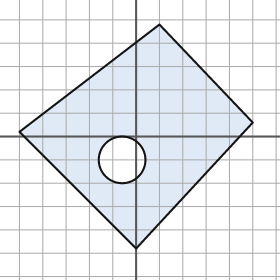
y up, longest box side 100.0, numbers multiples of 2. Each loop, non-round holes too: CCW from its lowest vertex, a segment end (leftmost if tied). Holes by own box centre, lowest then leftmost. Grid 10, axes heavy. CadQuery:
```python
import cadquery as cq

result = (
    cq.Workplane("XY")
    .moveTo(0.0, -48.0)
    .lineTo(50.0, 6.0)
    .lineTo(10.0, 48.0)
    .lineTo(-50.0, 2.0)
    .close()
    .moveTo(-6.0, -10.0)
    .circle(10.0)
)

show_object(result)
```